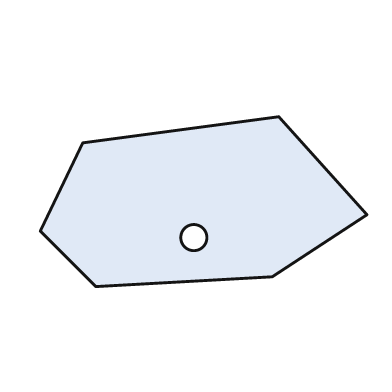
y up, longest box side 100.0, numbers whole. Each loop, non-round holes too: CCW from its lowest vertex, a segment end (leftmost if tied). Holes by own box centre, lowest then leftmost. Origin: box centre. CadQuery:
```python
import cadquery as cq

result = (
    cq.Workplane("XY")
    .moveTo(-33.0, -26.0)
    .lineTo(21.0, -23.0)
    .lineTo(50.0, -4.0)
    .lineTo(23.0, 26.0)
    .lineTo(-37.0, 18.0)
    .lineTo(-50.0, -9.0)
    .close()
    .moveTo(-3.0, -11.0)
    .circle(4.0)
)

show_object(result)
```